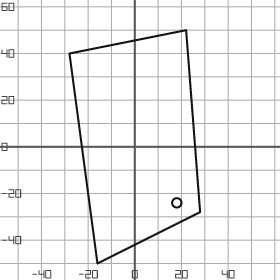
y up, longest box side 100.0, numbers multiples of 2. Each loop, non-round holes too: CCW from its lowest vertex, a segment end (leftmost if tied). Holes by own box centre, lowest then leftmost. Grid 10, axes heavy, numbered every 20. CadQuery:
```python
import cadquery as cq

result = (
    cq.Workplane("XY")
    .moveTo(-16.0, -50.0)
    .lineTo(28.0, -28.0)
    .lineTo(22.0, 50.0)
    .lineTo(-28.0, 40.0)
    .close()
    .moveTo(18.0, -24.0)
    .circle(2.0)
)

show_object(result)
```